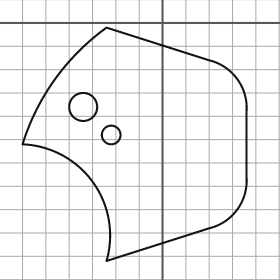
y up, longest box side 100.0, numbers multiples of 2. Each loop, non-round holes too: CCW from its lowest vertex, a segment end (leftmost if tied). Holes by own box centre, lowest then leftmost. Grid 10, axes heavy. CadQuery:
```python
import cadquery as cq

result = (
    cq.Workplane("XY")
    .moveTo(-24.0, -102.0)
    .lineTo(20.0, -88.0)
    .threePointArc((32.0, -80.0), (36.0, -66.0))
    .lineTo(36.0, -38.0)
    .threePointArc((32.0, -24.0), (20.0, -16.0))
    .lineTo(-24.0, -2.0)
    .threePointArc((-46.0, -24.0), (-60.0, -52.0))
    .threePointArc((-30.0, -68.0), (-24.0, -102.0))
    .close()
    .moveTo(-22.0, -48.0)
    .circle(4.0)
    .moveTo(-34.0, -36.0)
    .circle(6.0)
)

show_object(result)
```